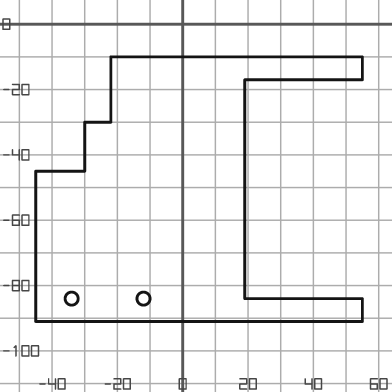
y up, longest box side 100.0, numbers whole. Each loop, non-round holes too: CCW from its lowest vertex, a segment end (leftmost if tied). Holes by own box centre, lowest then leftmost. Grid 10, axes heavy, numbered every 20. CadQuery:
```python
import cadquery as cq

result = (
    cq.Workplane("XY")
    .moveTo(-45.0, -91.0)
    .lineTo(55.0, -91.0)
    .lineTo(55.0, -84.0)
    .lineTo(19.0, -84.0)
    .lineTo(19.0, -17.0)
    .lineTo(55.0, -17.0)
    .lineTo(55.0, -10.0)
    .lineTo(-22.0, -10.0)
    .lineTo(-22.0, -30.0)
    .lineTo(-30.0, -30.0)
    .lineTo(-30.0, -45.0)
    .lineTo(-45.0, -45.0)
    .close()
    .moveTo(-34.0, -84.0)
    .circle(2.0)
    .moveTo(-12.0, -84.0)
    .circle(2.0)
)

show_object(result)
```